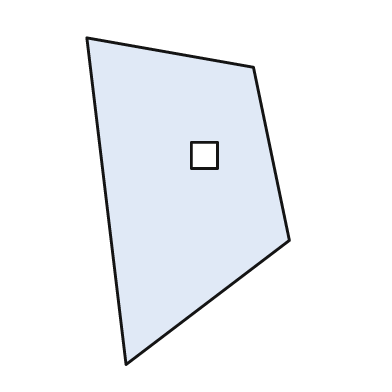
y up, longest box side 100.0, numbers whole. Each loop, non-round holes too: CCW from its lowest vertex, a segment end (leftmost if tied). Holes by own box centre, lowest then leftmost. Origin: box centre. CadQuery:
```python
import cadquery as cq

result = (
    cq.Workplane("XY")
    .moveTo(-19.0, -50.0)
    .lineTo(31.0, -12.0)
    .lineTo(20.0, 41.0)
    .lineTo(-31.0, 50.0)
    .close()
    .moveTo(1.0, 10.0)
    .lineTo(9.0, 10.0)
    .lineTo(9.0, 18.0)
    .lineTo(1.0, 18.0)
    .close()
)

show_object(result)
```